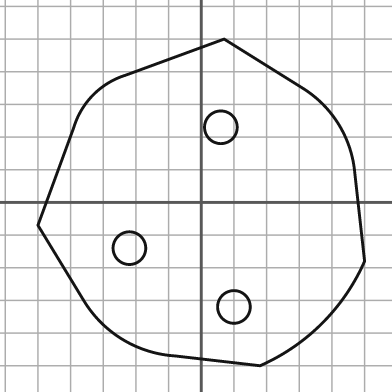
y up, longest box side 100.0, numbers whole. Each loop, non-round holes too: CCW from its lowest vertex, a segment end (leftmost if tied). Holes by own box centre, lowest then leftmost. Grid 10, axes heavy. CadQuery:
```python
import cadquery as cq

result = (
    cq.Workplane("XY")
    .moveTo(18.0, -50.0)
    .threePointArc((37.0, -37.0), (50.0, -18.0))
    .lineTo(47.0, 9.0)
    .threePointArc((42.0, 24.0), (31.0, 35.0))
    .lineTo(7.0, 50.0)
    .lineTo(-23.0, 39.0)
    .threePointArc((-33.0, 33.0), (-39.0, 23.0))
    .lineTo(-50.0, -7.0)
    .lineTo(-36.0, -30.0)
    .threePointArc((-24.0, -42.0), (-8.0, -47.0))
    .close()
    .moveTo(10.0, -32.0)
    .circle(5.0)
    .moveTo(-22.0, -14.0)
    .circle(5.0)
    .moveTo(6.0, 23.0)
    .circle(5.0)
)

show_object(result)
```